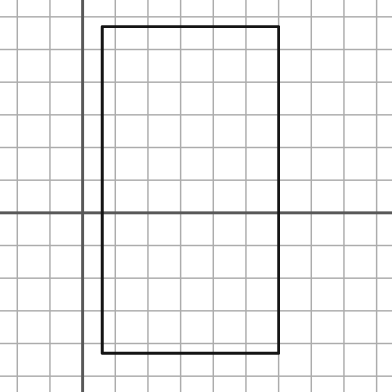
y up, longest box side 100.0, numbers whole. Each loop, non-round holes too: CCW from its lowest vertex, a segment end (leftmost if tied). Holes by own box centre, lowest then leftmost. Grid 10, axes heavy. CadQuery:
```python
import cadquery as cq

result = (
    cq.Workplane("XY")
    .moveTo(6.0, -43.0)
    .lineTo(60.0, -43.0)
    .lineTo(60.0, 57.0)
    .lineTo(6.0, 57.0)
    .close()
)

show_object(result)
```